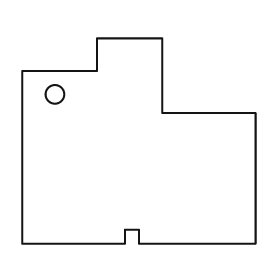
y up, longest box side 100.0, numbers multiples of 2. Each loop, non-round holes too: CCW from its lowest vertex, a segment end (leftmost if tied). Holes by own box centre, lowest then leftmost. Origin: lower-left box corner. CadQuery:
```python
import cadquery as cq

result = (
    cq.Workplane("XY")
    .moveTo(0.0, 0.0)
    .lineTo(44.0, 0.0)
    .lineTo(44.0, 6.0)
    .lineTo(50.0, 6.0)
    .lineTo(50.0, 0.0)
    .lineTo(100.0, 0.0)
    .lineTo(100.0, 56.0)
    .lineTo(60.0, 56.0)
    .lineTo(60.0, 88.0)
    .lineTo(32.0, 88.0)
    .lineTo(32.0, 74.0)
    .lineTo(0.0, 74.0)
    .close()
    .moveTo(14.0, 64.0)
    .circle(4.0)
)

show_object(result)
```